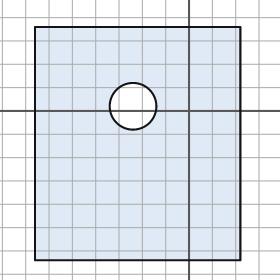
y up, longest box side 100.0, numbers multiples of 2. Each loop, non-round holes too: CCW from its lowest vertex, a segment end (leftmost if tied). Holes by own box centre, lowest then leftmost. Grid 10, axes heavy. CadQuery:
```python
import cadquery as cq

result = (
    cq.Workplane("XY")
    .moveTo(-66.0, -64.0)
    .lineTo(22.0, -64.0)
    .lineTo(22.0, 36.0)
    .lineTo(-66.0, 36.0)
    .close()
    .moveTo(-24.0, 2.0)
    .circle(10.0)
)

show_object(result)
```